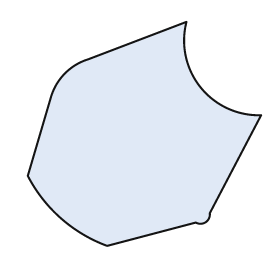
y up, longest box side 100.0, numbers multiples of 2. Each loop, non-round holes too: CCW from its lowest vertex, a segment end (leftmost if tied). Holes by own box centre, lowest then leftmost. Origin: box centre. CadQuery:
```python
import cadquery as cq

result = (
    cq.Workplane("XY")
    .moveTo(-16.0, -48.0)
    .lineTo(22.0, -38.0)
    .threePointArc((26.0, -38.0), (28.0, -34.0))
    .lineTo(50.0, 8.0)
    .threePointArc((24.0, 20.0), (18.0, 48.0))
    .lineTo(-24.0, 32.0)
    .threePointArc((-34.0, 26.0), (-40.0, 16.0))
    .lineTo(-50.0, -18.0)
    .threePointArc((-36.0, -36.0), (-16.0, -48.0))
    .close()
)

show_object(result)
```